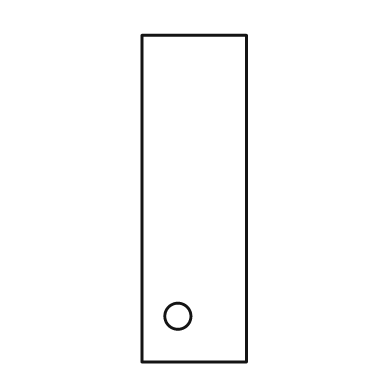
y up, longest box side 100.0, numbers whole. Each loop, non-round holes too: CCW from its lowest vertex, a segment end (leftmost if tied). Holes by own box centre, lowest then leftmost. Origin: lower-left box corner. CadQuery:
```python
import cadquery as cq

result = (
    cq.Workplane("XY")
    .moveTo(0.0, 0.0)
    .lineTo(32.0, 0.0)
    .lineTo(32.0, 100.0)
    .lineTo(0.0, 100.0)
    .close()
    .moveTo(11.0, 14.0)
    .circle(4.0)
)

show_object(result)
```